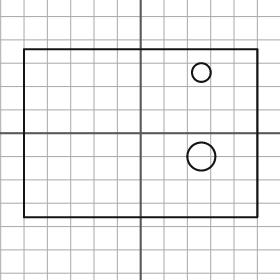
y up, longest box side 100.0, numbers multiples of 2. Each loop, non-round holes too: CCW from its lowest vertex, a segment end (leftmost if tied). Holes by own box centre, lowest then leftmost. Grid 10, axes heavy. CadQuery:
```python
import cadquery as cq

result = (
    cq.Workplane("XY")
    .moveTo(-50.0, -36.0)
    .lineTo(50.0, -36.0)
    .lineTo(50.0, 36.0)
    .lineTo(-50.0, 36.0)
    .close()
    .moveTo(26.0, -10.0)
    .circle(6.0)
    .moveTo(26.0, 26.0)
    .circle(4.0)
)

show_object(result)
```